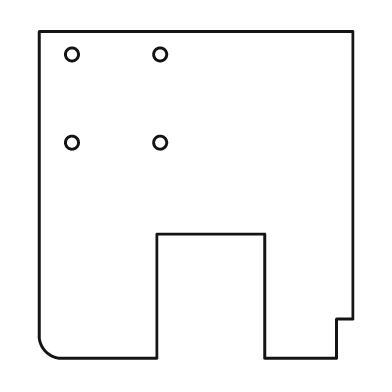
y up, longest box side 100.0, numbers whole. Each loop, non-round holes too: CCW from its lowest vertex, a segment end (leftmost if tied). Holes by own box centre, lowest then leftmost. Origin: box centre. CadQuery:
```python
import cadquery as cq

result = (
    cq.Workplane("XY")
    .moveTo(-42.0, -50.0)
    .lineTo(-12.0, -50.0)
    .lineTo(-12.0, -12.0)
    .lineTo(21.0, -12.0)
    .lineTo(21.0, -50.0)
    .lineTo(43.0, -50.0)
    .lineTo(43.0, -38.0)
    .lineTo(48.0, -38.0)
    .lineTo(48.0, 50.0)
    .lineTo(-48.0, 50.0)
    .lineTo(-48.0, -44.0)
    .threePointArc((-46.0, -48.0), (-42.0, -50.0))
    .close()
    .moveTo(-38.0, 16.0)
    .circle(2.0)
    .moveTo(-11.0, 16.0)
    .circle(2.0)
    .moveTo(-38.0, 43.0)
    .circle(2.0)
    .moveTo(-11.0, 43.0)
    .circle(2.0)
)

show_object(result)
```